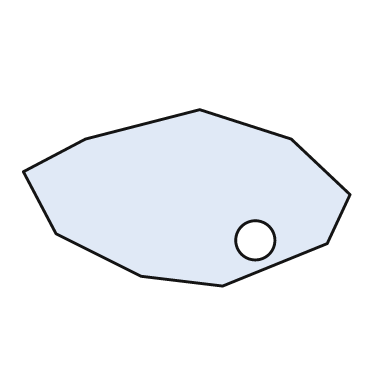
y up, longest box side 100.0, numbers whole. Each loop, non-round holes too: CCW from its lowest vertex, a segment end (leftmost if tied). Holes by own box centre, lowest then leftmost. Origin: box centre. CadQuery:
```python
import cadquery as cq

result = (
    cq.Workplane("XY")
    .moveTo(11.0, -27.0)
    .lineTo(43.0, -14.0)
    .lineTo(50.0, 1.0)
    .lineTo(32.0, 18.0)
    .lineTo(4.0, 27.0)
    .lineTo(-31.0, 18.0)
    .lineTo(-50.0, 8.0)
    .lineTo(-40.0, -11.0)
    .lineTo(-14.0, -24.0)
    .close()
    .moveTo(21.0, -13.0)
    .circle(6.0)
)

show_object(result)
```